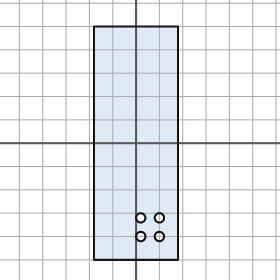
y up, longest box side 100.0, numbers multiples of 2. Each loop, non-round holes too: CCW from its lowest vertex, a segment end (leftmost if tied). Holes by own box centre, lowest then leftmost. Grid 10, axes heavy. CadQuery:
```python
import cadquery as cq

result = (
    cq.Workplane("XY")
    .moveTo(-18.0, -50.0)
    .lineTo(18.0, -50.0)
    .lineTo(18.0, 50.0)
    .lineTo(-18.0, 50.0)
    .close()
    .moveTo(2.0, -40.0)
    .circle(2.0)
    .moveTo(10.0, -40.0)
    .circle(2.0)
    .moveTo(2.0, -32.0)
    .circle(2.0)
    .moveTo(10.0, -32.0)
    .circle(2.0)
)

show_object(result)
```